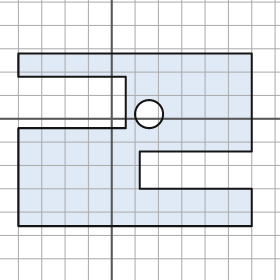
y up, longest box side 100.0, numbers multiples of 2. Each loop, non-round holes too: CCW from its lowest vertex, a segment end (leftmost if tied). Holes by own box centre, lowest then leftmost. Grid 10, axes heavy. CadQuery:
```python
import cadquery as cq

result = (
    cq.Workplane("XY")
    .moveTo(-40.0, -46.0)
    .lineTo(60.0, -46.0)
    .lineTo(60.0, -30.0)
    .lineTo(12.0, -30.0)
    .lineTo(12.0, -14.0)
    .lineTo(60.0, -14.0)
    .lineTo(60.0, 28.0)
    .lineTo(-40.0, 28.0)
    .lineTo(-40.0, 18.0)
    .lineTo(6.0, 18.0)
    .lineTo(6.0, -4.0)
    .lineTo(-40.0, -4.0)
    .close()
    .moveTo(16.0, 2.0)
    .circle(6.0)
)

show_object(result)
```